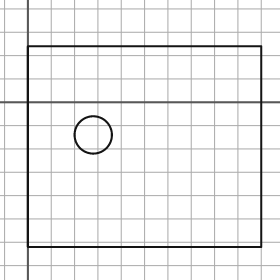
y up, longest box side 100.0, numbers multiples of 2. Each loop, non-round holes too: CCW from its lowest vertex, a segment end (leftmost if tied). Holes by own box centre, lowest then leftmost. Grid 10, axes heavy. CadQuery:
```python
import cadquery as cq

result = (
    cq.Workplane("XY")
    .moveTo(0.0, -62.0)
    .lineTo(100.0, -62.0)
    .lineTo(100.0, 24.0)
    .lineTo(0.0, 24.0)
    .close()
    .moveTo(28.0, -14.0)
    .circle(8.0)
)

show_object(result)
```